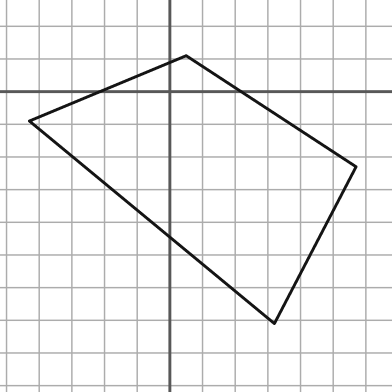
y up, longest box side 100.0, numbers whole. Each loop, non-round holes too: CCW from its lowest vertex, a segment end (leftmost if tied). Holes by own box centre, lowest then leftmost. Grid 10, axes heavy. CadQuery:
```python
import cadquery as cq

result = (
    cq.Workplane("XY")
    .moveTo(32.0, -71.0)
    .lineTo(57.0, -23.0)
    .lineTo(5.0, 11.0)
    .lineTo(-43.0, -9.0)
    .close()
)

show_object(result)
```